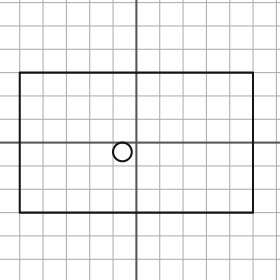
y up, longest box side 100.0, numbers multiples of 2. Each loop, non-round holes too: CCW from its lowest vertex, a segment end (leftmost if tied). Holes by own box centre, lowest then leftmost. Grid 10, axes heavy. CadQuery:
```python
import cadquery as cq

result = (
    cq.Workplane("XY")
    .moveTo(-50.0, -30.0)
    .lineTo(50.0, -30.0)
    .lineTo(50.0, 30.0)
    .lineTo(-50.0, 30.0)
    .close()
    .moveTo(-6.0, -4.0)
    .circle(4.0)
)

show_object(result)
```